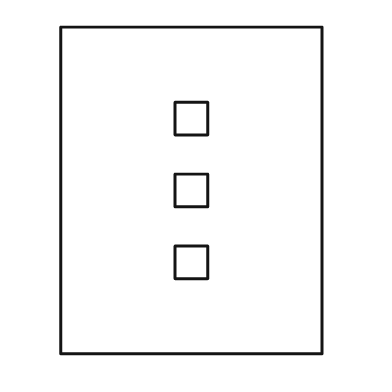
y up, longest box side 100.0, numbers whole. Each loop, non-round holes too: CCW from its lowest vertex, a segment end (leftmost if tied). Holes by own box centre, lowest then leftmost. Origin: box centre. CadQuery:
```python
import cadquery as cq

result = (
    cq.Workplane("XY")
    .moveTo(-40.0, -50.0)
    .lineTo(40.0, -50.0)
    .lineTo(40.0, 50.0)
    .lineTo(-40.0, 50.0)
    .close()
    .moveTo(-5.0, -27.0)
    .lineTo(5.0, -27.0)
    .lineTo(5.0, -17.0)
    .lineTo(-5.0, -17.0)
    .close()
    .moveTo(-5.0, -5.0)
    .lineTo(5.0, -5.0)
    .lineTo(5.0, 5.0)
    .lineTo(-5.0, 5.0)
    .close()
    .moveTo(-5.0, 17.0)
    .lineTo(5.0, 17.0)
    .lineTo(5.0, 27.0)
    .lineTo(-5.0, 27.0)
    .close()
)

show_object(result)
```